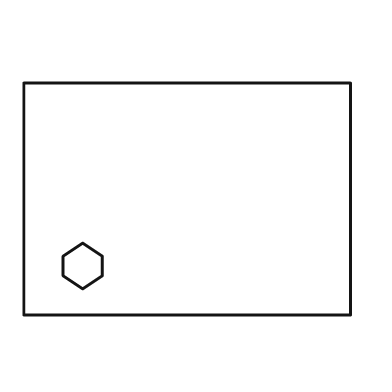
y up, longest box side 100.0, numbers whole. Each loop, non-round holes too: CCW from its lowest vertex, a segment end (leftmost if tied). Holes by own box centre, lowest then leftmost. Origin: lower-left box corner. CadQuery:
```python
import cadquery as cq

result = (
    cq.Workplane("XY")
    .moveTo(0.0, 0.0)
    .lineTo(100.0, 0.0)
    .lineTo(100.0, 71.0)
    .lineTo(0.0, 71.0)
    .close()
    .moveTo(18.0, 8.0)
    .lineTo(24.0, 12.0)
    .lineTo(24.0, 18.0)
    .lineTo(18.0, 22.0)
    .lineTo(12.0, 18.0)
    .lineTo(12.0, 12.0)
    .close()
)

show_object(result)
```